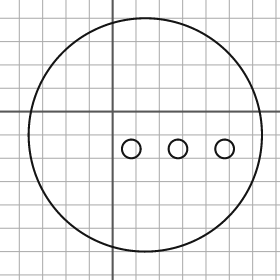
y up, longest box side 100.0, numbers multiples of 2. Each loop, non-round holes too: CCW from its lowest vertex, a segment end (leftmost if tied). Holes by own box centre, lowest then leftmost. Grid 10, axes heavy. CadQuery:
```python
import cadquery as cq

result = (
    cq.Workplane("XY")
    .moveTo(14.0, -10.0)
    .circle(50.0)
    .moveTo(8.0, -16.0)
    .circle(4.0)
    .moveTo(28.0, -16.0)
    .circle(4.0)
    .moveTo(48.0, -16.0)
    .circle(4.0)
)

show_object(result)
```